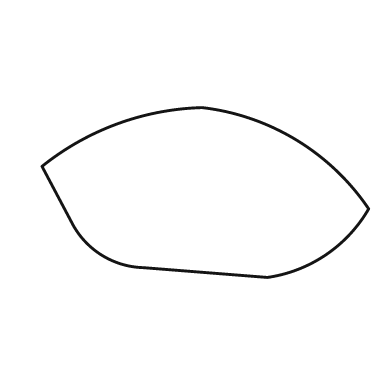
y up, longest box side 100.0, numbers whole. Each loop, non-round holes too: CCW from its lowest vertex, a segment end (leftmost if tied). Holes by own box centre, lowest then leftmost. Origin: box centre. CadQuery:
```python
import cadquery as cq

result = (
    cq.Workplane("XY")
    .moveTo(19.0, -26.0)
    .threePointArc((37.0, -19.0), (50.0, -5.0))
    .threePointArc((28.0, 16.0), (-1.0, 26.0))
    .threePointArc((-27.0, 21.0), (-50.0, 8.0))
    .lineTo(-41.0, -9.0)
    .threePointArc((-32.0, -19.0), (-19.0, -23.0))
    .close()
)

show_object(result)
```